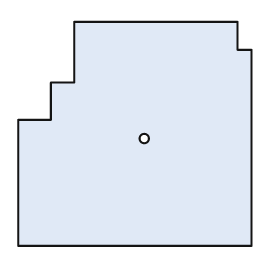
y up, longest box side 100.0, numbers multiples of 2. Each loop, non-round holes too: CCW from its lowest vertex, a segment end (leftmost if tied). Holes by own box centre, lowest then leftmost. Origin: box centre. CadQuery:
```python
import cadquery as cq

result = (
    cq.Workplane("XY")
    .moveTo(-50.0, -48.0)
    .lineTo(50.0, -48.0)
    .lineTo(50.0, 36.0)
    .lineTo(44.0, 36.0)
    .lineTo(44.0, 48.0)
    .lineTo(-26.0, 48.0)
    .lineTo(-26.0, 22.0)
    .lineTo(-36.0, 22.0)
    .lineTo(-36.0, 6.0)
    .lineTo(-50.0, 6.0)
    .close()
    .moveTo(4.0, -2.0)
    .circle(2.0)
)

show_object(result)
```